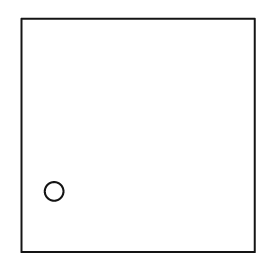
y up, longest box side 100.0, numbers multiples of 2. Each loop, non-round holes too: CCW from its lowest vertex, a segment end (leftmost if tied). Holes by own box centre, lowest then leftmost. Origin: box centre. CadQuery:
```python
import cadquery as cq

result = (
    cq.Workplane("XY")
    .moveTo(-50.0, -50.0)
    .lineTo(50.0, -50.0)
    .lineTo(50.0, 50.0)
    .lineTo(-50.0, 50.0)
    .close()
    .moveTo(-36.0, -24.0)
    .circle(4.0)
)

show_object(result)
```